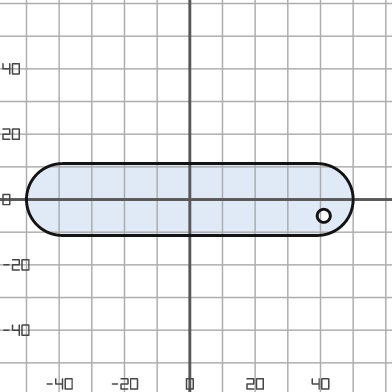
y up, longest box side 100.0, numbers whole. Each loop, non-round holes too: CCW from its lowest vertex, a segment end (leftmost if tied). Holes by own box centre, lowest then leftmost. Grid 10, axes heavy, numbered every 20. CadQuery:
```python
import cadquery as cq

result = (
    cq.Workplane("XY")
    .moveTo(-39.0, -11.0)
    .lineTo(39.0, -11.0)
    .threePointArc((50.0, 0.0), (39.0, 11.0))
    .lineTo(-39.0, 11.0)
    .threePointArc((-50.0, 0.0), (-39.0, -11.0))
    .close()
    .moveTo(41.0, -5.0)
    .circle(2.0)
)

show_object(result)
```